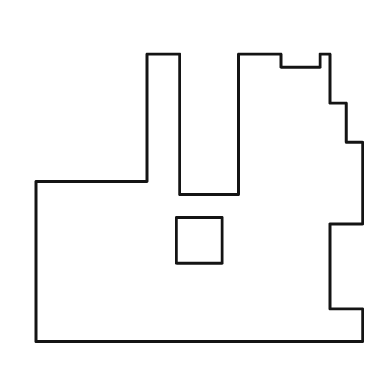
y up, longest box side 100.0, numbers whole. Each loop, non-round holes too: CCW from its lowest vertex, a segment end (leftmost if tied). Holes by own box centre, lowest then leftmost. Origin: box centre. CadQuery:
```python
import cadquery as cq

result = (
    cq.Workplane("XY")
    .moveTo(-50.0, -44.0)
    .lineTo(50.0, -44.0)
    .lineTo(50.0, -34.0)
    .lineTo(40.0, -34.0)
    .lineTo(40.0, -8.0)
    .lineTo(50.0, -8.0)
    .lineTo(50.0, 17.0)
    .lineTo(45.0, 17.0)
    .lineTo(45.0, 29.0)
    .lineTo(40.0, 29.0)
    .lineTo(40.0, 44.0)
    .lineTo(37.0, 44.0)
    .lineTo(37.0, 40.0)
    .lineTo(25.0, 40.0)
    .lineTo(25.0, 44.0)
    .lineTo(12.0, 44.0)
    .lineTo(12.0, 1.0)
    .lineTo(-6.0, 1.0)
    .lineTo(-6.0, 44.0)
    .lineTo(-16.0, 44.0)
    .lineTo(-16.0, 5.0)
    .lineTo(-50.0, 5.0)
    .close()
    .moveTo(-7.0, -20.0)
    .lineTo(7.0, -20.0)
    .lineTo(7.0, -6.0)
    .lineTo(-7.0, -6.0)
    .close()
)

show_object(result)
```